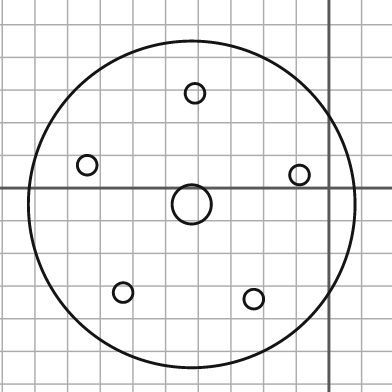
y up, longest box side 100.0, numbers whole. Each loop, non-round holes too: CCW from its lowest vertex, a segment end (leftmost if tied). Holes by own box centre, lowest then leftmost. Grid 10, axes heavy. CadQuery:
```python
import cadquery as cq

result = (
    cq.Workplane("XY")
    .moveTo(-42.0, -5.0)
    .circle(50.0)
    .moveTo(-23.0, -34.0)
    .circle(3.0)
    .moveTo(-63.0, -32.0)
    .circle(3.0)
    .moveTo(-42.0, -5.0)
    .circle(6.0)
    .moveTo(-9.0, 4.0)
    .circle(3.0)
    .moveTo(-74.0, 7.0)
    .circle(3.0)
    .moveTo(-41.0, 29.0)
    .circle(3.0)
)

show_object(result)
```